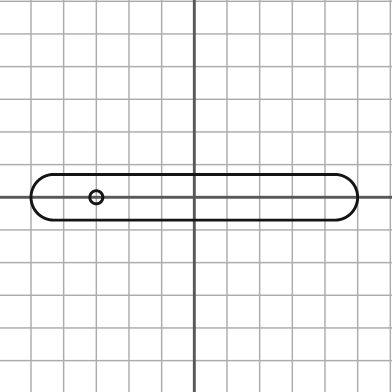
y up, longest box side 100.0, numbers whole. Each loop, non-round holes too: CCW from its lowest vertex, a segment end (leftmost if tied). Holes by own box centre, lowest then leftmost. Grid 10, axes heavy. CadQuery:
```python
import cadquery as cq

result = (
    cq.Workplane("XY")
    .moveTo(-43.0, -7.0)
    .lineTo(43.0, -7.0)
    .threePointArc((50.0, 0.0), (43.0, 7.0))
    .lineTo(-43.0, 7.0)
    .threePointArc((-50.0, 0.0), (-43.0, -7.0))
    .close()
    .moveTo(-30.0, 0.0)
    .circle(2.0)
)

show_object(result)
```